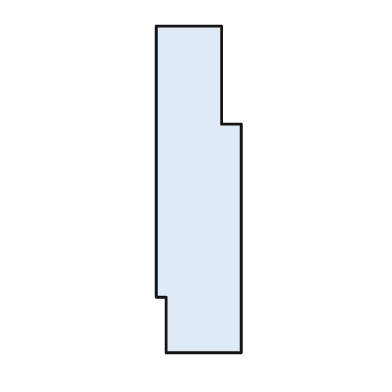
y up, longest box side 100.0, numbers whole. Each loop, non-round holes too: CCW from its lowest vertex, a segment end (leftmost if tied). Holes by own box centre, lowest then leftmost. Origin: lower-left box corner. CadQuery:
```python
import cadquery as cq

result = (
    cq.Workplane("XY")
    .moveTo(3.0, 0.0)
    .lineTo(26.0, 0.0)
    .lineTo(26.0, 70.0)
    .lineTo(20.0, 70.0)
    .lineTo(20.0, 100.0)
    .lineTo(0.0, 100.0)
    .lineTo(0.0, 17.0)
    .lineTo(3.0, 17.0)
    .close()
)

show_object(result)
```